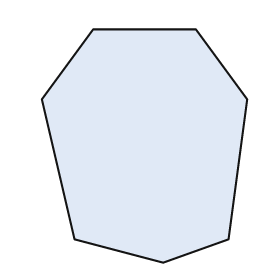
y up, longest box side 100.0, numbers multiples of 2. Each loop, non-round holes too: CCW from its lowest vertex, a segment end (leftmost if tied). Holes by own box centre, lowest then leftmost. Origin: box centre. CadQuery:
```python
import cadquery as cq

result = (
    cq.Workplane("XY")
    .moveTo(8.0, -50.0)
    .lineTo(36.0, -40.0)
    .lineTo(44.0, 20.0)
    .lineTo(22.0, 50.0)
    .lineTo(-22.0, 50.0)
    .lineTo(-44.0, 20.0)
    .lineTo(-30.0, -40.0)
    .close()
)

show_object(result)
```